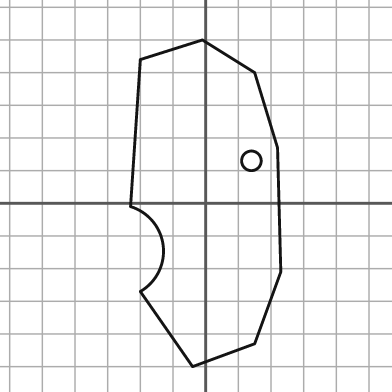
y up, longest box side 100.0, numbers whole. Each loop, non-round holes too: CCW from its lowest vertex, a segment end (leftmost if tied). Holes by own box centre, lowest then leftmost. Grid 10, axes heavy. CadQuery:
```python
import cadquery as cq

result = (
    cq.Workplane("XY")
    .moveTo(-4.0, -50.0)
    .lineTo(15.0, -43.0)
    .lineTo(23.0, -21.0)
    .lineTo(22.0, 17.0)
    .lineTo(15.0, 40.0)
    .lineTo(-1.0, 50.0)
    .lineTo(-20.0, 44.0)
    .lineTo(-23.0, -1.0)
    .threePointArc((-13.0, -13.0), (-20.0, -27.0))
    .close()
    .moveTo(14.0, 13.0)
    .circle(3.0)
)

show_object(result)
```